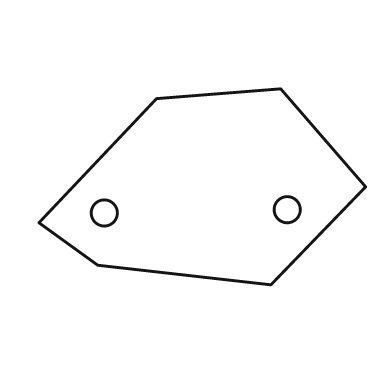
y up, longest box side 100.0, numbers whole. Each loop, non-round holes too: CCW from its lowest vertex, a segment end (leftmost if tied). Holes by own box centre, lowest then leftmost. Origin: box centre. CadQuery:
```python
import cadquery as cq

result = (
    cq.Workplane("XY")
    .moveTo(21.0, -30.0)
    .lineTo(50.0, 0.0)
    .lineTo(24.0, 30.0)
    .lineTo(-14.0, 27.0)
    .lineTo(-50.0, -11.0)
    .lineTo(-32.0, -24.0)
    .close()
    .moveTo(-30.0, -8.0)
    .circle(4.0)
    .moveTo(26.0, -7.0)
    .circle(4.0)
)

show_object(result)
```